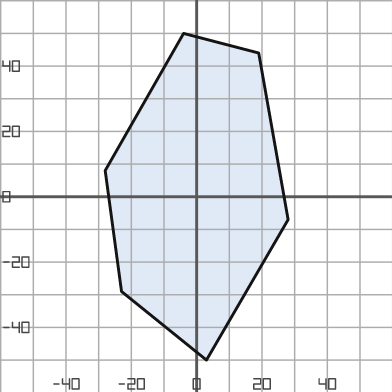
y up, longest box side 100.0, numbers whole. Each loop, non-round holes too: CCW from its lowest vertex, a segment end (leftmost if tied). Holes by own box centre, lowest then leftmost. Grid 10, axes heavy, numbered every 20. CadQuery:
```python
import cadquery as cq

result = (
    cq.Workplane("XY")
    .moveTo(3.0, -50.0)
    .lineTo(28.0, -7.0)
    .lineTo(19.0, 44.0)
    .lineTo(-4.0, 50.0)
    .lineTo(-28.0, 8.0)
    .lineTo(-23.0, -29.0)
    .close()
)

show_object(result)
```